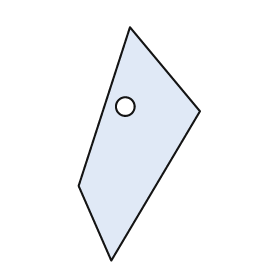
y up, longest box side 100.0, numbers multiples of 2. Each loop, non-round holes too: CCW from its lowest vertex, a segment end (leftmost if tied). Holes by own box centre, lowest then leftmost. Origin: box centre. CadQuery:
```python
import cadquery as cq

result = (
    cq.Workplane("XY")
    .moveTo(-12.0, -50.0)
    .lineTo(26.0, 14.0)
    .lineTo(-4.0, 50.0)
    .lineTo(-26.0, -18.0)
    .close()
    .moveTo(-6.0, 16.0)
    .circle(4.0)
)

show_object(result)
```